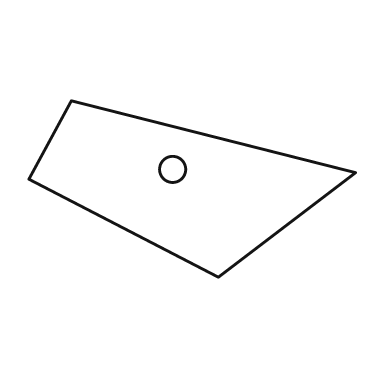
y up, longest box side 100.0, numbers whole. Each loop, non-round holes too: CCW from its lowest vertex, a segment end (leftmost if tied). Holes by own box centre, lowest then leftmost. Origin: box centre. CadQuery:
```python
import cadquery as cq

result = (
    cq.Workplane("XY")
    .moveTo(8.0, -27.0)
    .lineTo(50.0, 5.0)
    .lineTo(-37.0, 27.0)
    .lineTo(-50.0, 3.0)
    .close()
    .moveTo(-6.0, 6.0)
    .circle(4.0)
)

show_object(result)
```